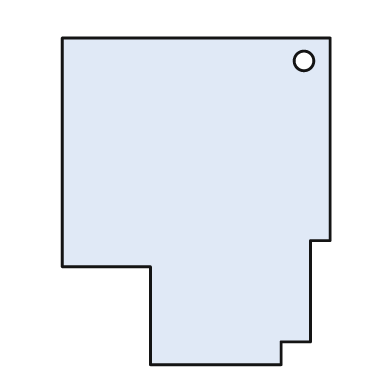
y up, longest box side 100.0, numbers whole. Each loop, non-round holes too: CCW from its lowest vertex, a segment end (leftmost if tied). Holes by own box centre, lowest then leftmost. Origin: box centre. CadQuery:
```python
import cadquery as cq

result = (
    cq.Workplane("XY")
    .moveTo(-14.0, -50.0)
    .lineTo(26.0, -50.0)
    .lineTo(26.0, -43.0)
    .lineTo(35.0, -43.0)
    .lineTo(35.0, -12.0)
    .lineTo(41.0, -12.0)
    .lineTo(41.0, 50.0)
    .lineTo(-41.0, 50.0)
    .lineTo(-41.0, -20.0)
    .lineTo(-14.0, -20.0)
    .close()
    .moveTo(33.0, 43.0)
    .circle(3.0)
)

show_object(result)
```